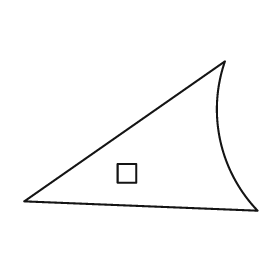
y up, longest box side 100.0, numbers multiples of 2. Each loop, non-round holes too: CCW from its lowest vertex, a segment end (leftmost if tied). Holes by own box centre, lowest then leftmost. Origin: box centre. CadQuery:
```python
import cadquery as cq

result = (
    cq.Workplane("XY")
    .moveTo(50.0, -32.0)
    .threePointArc((34.0, -2.0), (36.0, 32.0))
    .lineTo(-50.0, -28.0)
    .close()
    .moveTo(-10.0, -20.0)
    .lineTo(-2.0, -20.0)
    .lineTo(-2.0, -12.0)
    .lineTo(-10.0, -12.0)
    .close()
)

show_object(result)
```